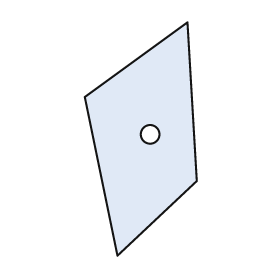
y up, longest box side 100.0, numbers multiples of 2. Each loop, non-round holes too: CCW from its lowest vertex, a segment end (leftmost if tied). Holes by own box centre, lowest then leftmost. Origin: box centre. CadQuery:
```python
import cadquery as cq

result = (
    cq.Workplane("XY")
    .moveTo(-10.0, -50.0)
    .lineTo(24.0, -18.0)
    .lineTo(20.0, 50.0)
    .lineTo(-24.0, 18.0)
    .close()
    .moveTo(4.0, 2.0)
    .circle(4.0)
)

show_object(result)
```